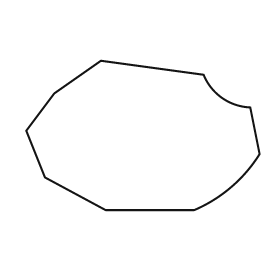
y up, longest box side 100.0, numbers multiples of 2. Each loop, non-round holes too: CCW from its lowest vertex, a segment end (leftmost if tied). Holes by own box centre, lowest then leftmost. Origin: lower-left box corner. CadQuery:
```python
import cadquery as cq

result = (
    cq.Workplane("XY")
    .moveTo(34.0, 0.0)
    .lineTo(72.0, 0.0)
    .threePointArc((88.0, 10.0), (100.0, 24.0))
    .lineTo(96.0, 44.0)
    .threePointArc((84.0, 48.0), (76.0, 58.0))
    .lineTo(32.0, 64.0)
    .lineTo(12.0, 50.0)
    .lineTo(0.0, 34.0)
    .lineTo(8.0, 14.0)
    .close()
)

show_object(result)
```